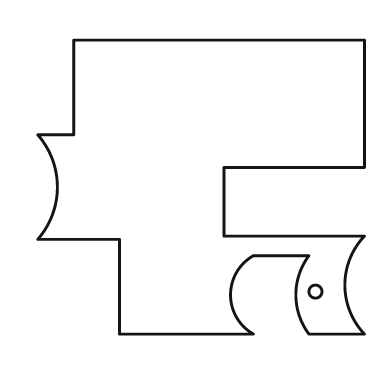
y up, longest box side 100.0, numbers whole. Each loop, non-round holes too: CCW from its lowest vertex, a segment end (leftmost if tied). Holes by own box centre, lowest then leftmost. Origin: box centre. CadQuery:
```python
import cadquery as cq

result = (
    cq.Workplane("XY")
    .moveTo(-25.0, -45.0)
    .lineTo(16.0, -45.0)
    .threePointArc((9.0, -33.0), (16.0, -21.0))
    .lineTo(33.0, -21.0)
    .threePointArc((29.0, -33.0), (33.0, -45.0))
    .lineTo(50.0, -45.0)
    .threePointArc((44.0, -30.0), (50.0, -15.0))
    .lineTo(7.0, -15.0)
    .lineTo(7.0, 6.0)
    .lineTo(50.0, 6.0)
    .lineTo(50.0, 45.0)
    .lineTo(-39.0, 45.0)
    .lineTo(-39.0, 16.0)
    .lineTo(-50.0, 16.0)
    .threePointArc((-44.0, 0.0), (-50.0, -16.0))
    .lineTo(-25.0, -16.0)
    .close()
    .moveTo(35.0, -32.0)
    .circle(2.0)
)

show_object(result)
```